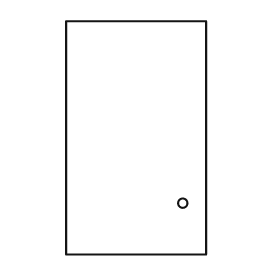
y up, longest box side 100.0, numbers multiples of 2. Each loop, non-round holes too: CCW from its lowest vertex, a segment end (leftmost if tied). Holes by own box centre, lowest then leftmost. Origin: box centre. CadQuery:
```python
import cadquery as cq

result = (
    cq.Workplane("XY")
    .moveTo(-30.0, -50.0)
    .lineTo(30.0, -50.0)
    .lineTo(30.0, 50.0)
    .lineTo(-30.0, 50.0)
    .close()
    .moveTo(20.0, -28.0)
    .circle(2.0)
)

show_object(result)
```